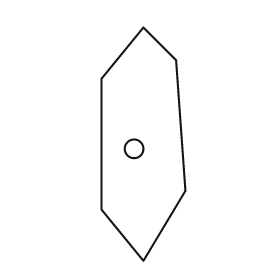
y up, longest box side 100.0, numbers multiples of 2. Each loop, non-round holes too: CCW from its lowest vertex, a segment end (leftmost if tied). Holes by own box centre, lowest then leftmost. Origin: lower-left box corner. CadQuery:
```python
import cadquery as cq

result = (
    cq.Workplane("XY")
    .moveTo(18.0, 0.0)
    .lineTo(36.0, 30.0)
    .lineTo(32.0, 86.0)
    .lineTo(18.0, 100.0)
    .lineTo(0.0, 78.0)
    .lineTo(0.0, 22.0)
    .close()
    .moveTo(14.0, 48.0)
    .circle(4.0)
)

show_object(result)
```